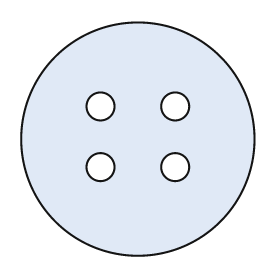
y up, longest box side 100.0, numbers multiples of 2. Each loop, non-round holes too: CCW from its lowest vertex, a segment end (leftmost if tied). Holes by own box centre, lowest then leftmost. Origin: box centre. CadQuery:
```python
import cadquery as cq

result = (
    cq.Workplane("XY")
    .moveTo(0.0, 0.0)
    .circle(50.0)
    .moveTo(-16.0, -12.0)
    .circle(6.0)
    .moveTo(16.0, -12.0)
    .circle(6.0)
    .moveTo(-16.0, 14.0)
    .circle(6.0)
    .moveTo(16.0, 14.0)
    .circle(6.0)
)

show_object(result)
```